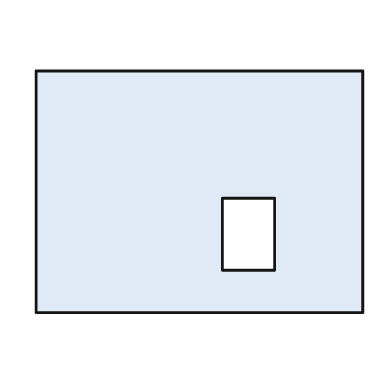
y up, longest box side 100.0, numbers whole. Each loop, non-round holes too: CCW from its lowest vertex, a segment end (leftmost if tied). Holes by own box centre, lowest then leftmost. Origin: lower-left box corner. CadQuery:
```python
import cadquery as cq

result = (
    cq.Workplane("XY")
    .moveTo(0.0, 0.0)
    .lineTo(100.0, 0.0)
    .lineTo(100.0, 74.0)
    .lineTo(0.0, 74.0)
    .close()
    .moveTo(57.0, 13.0)
    .lineTo(73.0, 13.0)
    .lineTo(73.0, 35.0)
    .lineTo(57.0, 35.0)
    .close()
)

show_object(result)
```